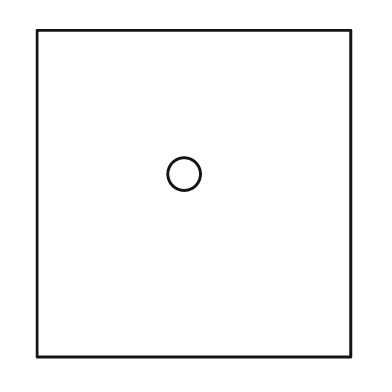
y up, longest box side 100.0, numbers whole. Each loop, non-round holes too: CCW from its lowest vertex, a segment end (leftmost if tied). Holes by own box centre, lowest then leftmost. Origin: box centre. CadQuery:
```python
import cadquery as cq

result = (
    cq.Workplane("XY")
    .moveTo(-48.0, -50.0)
    .lineTo(48.0, -50.0)
    .lineTo(48.0, 50.0)
    .lineTo(-48.0, 50.0)
    .close()
    .moveTo(-3.0, 6.0)
    .circle(5.0)
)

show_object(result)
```